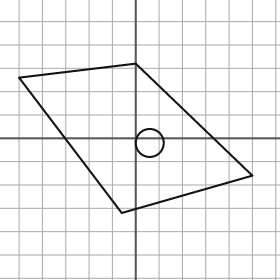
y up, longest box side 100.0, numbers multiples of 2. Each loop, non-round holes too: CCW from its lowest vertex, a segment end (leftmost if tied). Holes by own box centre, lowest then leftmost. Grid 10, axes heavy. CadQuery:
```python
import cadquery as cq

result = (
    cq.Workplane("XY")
    .moveTo(-6.0, -32.0)
    .lineTo(50.0, -16.0)
    .lineTo(0.0, 32.0)
    .lineTo(-50.0, 26.0)
    .close()
    .moveTo(6.0, -2.0)
    .circle(6.0)
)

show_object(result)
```